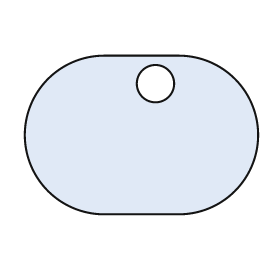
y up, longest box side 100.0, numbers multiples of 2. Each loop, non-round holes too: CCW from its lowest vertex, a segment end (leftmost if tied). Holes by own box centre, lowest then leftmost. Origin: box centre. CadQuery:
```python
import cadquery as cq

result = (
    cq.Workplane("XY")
    .moveTo(-16.0, -34.0)
    .lineTo(16.0, -34.0)
    .threePointArc((50.0, 0.0), (16.0, 34.0))
    .lineTo(-16.0, 34.0)
    .threePointArc((-50.0, 0.0), (-16.0, -34.0))
    .close()
    .moveTo(6.0, 22.0)
    .circle(8.0)
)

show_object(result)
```